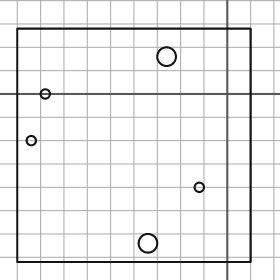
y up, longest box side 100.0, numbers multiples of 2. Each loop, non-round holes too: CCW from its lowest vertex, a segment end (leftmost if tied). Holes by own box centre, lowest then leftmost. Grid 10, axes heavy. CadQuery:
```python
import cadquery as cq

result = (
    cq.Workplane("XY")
    .moveTo(-90.0, -72.0)
    .lineTo(10.0, -72.0)
    .lineTo(10.0, 28.0)
    .lineTo(-90.0, 28.0)
    .close()
    .moveTo(-34.0, -64.0)
    .circle(4.0)
    .moveTo(-12.0, -40.0)
    .circle(2.0)
    .moveTo(-84.0, -20.0)
    .circle(2.0)
    .moveTo(-78.0, 0.0)
    .circle(2.0)
    .moveTo(-26.0, 16.0)
    .circle(4.0)
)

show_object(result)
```